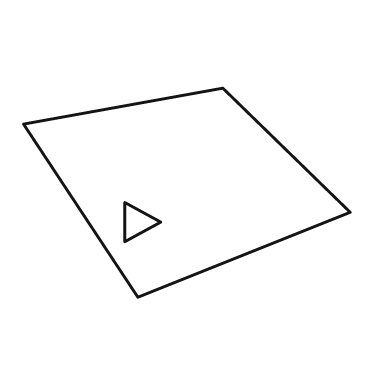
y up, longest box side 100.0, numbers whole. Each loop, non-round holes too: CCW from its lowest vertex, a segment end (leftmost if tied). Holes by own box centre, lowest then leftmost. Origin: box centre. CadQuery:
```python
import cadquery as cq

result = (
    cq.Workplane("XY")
    .moveTo(-15.0, -32.0)
    .lineTo(50.0, -6.0)
    .lineTo(11.0, 32.0)
    .lineTo(-50.0, 21.0)
    .close()
    .moveTo(-19.0, -15.0)
    .lineTo(-8.0, -9.0)
    .lineTo(-19.0, -3.0)
    .close()
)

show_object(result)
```